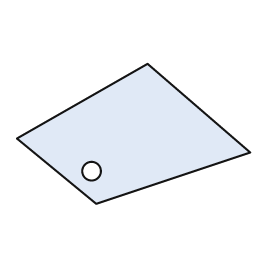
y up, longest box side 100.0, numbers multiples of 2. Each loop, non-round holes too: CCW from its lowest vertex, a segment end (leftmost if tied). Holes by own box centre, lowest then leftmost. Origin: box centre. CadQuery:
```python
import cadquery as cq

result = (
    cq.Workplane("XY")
    .moveTo(-16.0, -30.0)
    .lineTo(50.0, -8.0)
    .lineTo(6.0, 30.0)
    .lineTo(-50.0, -2.0)
    .close()
    .moveTo(-18.0, -16.0)
    .circle(4.0)
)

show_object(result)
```